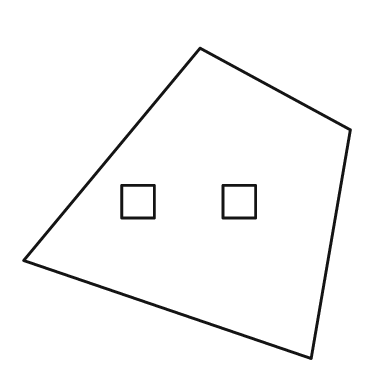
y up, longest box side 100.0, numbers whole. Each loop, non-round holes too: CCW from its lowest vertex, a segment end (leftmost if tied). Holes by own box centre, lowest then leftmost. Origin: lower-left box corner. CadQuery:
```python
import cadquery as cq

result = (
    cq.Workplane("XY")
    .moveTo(88.0, 0.0)
    .lineTo(100.0, 70.0)
    .lineTo(54.0, 95.0)
    .lineTo(0.0, 30.0)
    .close()
    .moveTo(30.0, 43.0)
    .lineTo(40.0, 43.0)
    .lineTo(40.0, 53.0)
    .lineTo(30.0, 53.0)
    .close()
    .moveTo(61.0, 43.0)
    .lineTo(71.0, 43.0)
    .lineTo(71.0, 53.0)
    .lineTo(61.0, 53.0)
    .close()
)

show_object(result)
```